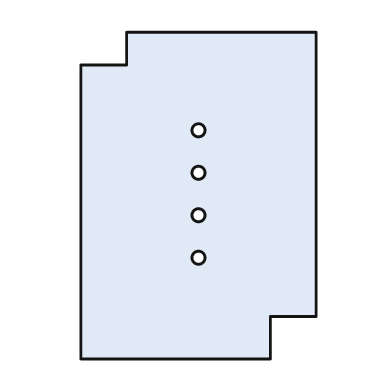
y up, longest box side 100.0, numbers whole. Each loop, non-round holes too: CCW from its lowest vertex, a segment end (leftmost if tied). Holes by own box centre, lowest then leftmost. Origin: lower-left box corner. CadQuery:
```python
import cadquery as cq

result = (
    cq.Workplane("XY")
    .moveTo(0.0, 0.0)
    .lineTo(58.0, 0.0)
    .lineTo(58.0, 13.0)
    .lineTo(72.0, 13.0)
    .lineTo(72.0, 100.0)
    .lineTo(14.0, 100.0)
    .lineTo(14.0, 90.0)
    .lineTo(0.0, 90.0)
    .close()
    .moveTo(36.0, 31.0)
    .circle(2.0)
    .moveTo(36.0, 44.0)
    .circle(2.0)
    .moveTo(36.0, 57.0)
    .circle(2.0)
    .moveTo(36.0, 70.0)
    .circle(2.0)
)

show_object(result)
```